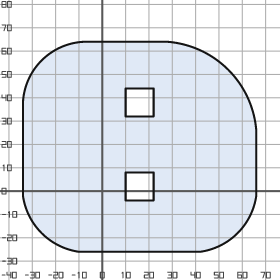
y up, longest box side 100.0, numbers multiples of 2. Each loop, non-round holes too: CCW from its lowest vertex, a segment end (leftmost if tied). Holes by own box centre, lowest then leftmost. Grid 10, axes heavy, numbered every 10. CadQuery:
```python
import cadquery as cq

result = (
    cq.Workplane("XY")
    .moveTo(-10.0, -26.0)
    .lineTo(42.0, -26.0)
    .threePointArc((58.0, -18.0), (66.0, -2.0))
    .lineTo(66.0, 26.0)
    .threePointArc((54.0, 52.0), (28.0, 64.0))
    .lineTo(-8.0, 64.0)
    .threePointArc((-26.0, 56.0), (-34.0, 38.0))
    .lineTo(-34.0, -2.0)
    .threePointArc((-26.0, -18.0), (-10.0, -26.0))
    .close()
    .moveTo(10.0, -4.0)
    .lineTo(22.0, -4.0)
    .lineTo(22.0, 8.0)
    .lineTo(10.0, 8.0)
    .close()
    .moveTo(10.0, 32.0)
    .lineTo(22.0, 32.0)
    .lineTo(22.0, 44.0)
    .lineTo(10.0, 44.0)
    .close()
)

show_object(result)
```